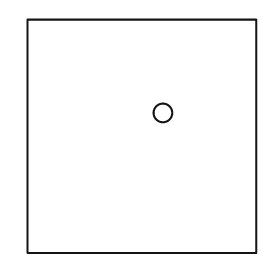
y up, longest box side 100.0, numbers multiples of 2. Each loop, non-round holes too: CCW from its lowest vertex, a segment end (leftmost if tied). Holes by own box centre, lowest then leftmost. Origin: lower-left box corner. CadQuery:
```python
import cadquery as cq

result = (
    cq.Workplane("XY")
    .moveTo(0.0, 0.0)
    .lineTo(98.0, 0.0)
    .lineTo(98.0, 100.0)
    .lineTo(0.0, 100.0)
    .close()
    .moveTo(58.0, 60.0)
    .circle(4.0)
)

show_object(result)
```